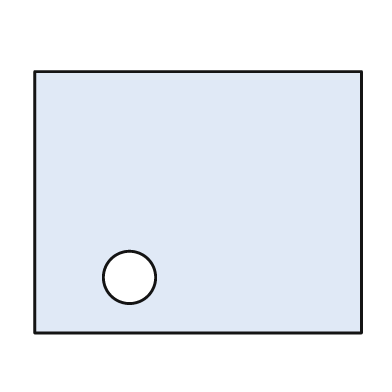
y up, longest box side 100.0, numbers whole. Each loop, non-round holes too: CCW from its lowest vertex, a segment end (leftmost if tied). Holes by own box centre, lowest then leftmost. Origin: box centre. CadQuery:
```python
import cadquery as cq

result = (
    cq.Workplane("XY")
    .moveTo(-50.0, -40.0)
    .lineTo(50.0, -40.0)
    .lineTo(50.0, 40.0)
    .lineTo(-50.0, 40.0)
    .close()
    .moveTo(-21.0, -23.0)
    .circle(8.0)
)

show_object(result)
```